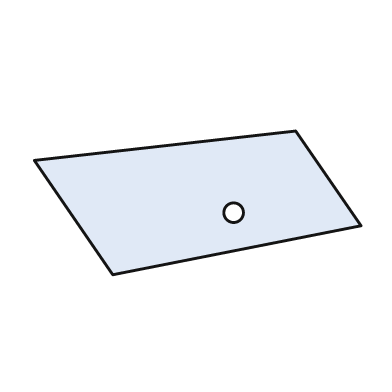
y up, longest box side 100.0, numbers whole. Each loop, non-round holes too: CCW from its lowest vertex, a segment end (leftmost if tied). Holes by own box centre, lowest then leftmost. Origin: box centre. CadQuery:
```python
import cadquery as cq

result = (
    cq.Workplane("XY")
    .moveTo(-26.0, -22.0)
    .lineTo(50.0, -7.0)
    .lineTo(30.0, 22.0)
    .lineTo(-50.0, 13.0)
    .close()
    .moveTo(11.0, -3.0)
    .circle(3.0)
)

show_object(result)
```